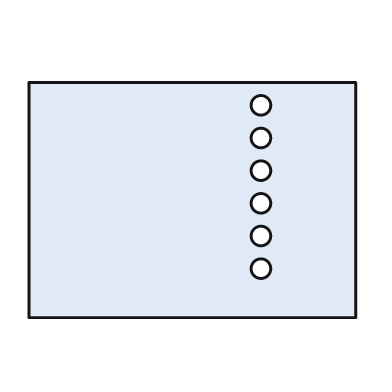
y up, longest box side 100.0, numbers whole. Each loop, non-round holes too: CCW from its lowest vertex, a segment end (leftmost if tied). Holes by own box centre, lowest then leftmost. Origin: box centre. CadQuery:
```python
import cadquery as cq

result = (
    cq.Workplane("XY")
    .moveTo(-50.0, -36.0)
    .lineTo(50.0, -36.0)
    .lineTo(50.0, 36.0)
    .lineTo(-50.0, 36.0)
    .close()
    .moveTo(21.0, -21.0)
    .circle(3.0)
    .moveTo(21.0, -11.0)
    .circle(3.0)
    .moveTo(21.0, -1.0)
    .circle(3.0)
    .moveTo(21.0, 9.0)
    .circle(3.0)
    .moveTo(21.0, 19.0)
    .circle(3.0)
    .moveTo(21.0, 29.0)
    .circle(3.0)
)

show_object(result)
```